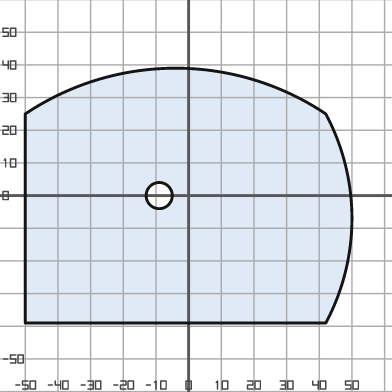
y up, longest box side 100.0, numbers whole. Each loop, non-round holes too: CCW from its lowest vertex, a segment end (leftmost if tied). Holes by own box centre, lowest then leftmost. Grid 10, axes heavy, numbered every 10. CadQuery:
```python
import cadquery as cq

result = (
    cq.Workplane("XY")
    .moveTo(-50.0, -39.0)
    .lineTo(42.0, -39.0)
    .threePointArc((50.0, -7.0), (42.0, 25.0))
    .threePointArc((-4.0, 39.0), (-50.0, 25.0))
    .close()
    .moveTo(-9.0, 0.0)
    .circle(4.0)
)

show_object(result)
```